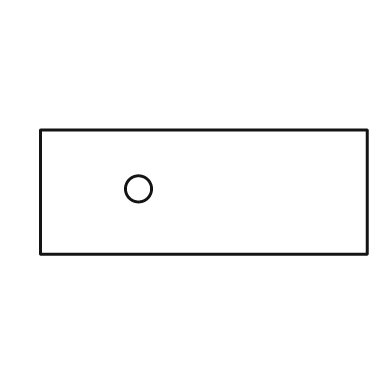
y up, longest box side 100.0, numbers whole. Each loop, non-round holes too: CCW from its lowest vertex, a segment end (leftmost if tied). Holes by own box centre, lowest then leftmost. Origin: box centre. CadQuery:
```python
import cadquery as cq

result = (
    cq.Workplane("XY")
    .moveTo(-50.0, -19.0)
    .lineTo(50.0, -19.0)
    .lineTo(50.0, 19.0)
    .lineTo(-50.0, 19.0)
    .close()
    .moveTo(-20.0, 1.0)
    .circle(4.0)
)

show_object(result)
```